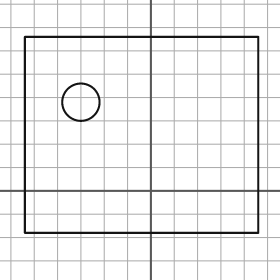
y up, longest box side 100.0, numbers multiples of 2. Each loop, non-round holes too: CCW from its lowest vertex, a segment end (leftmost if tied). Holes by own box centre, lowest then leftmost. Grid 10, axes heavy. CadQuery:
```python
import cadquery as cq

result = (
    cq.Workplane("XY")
    .moveTo(-54.0, -18.0)
    .lineTo(46.0, -18.0)
    .lineTo(46.0, 66.0)
    .lineTo(-54.0, 66.0)
    .close()
    .moveTo(-30.0, 38.0)
    .circle(8.0)
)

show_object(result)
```